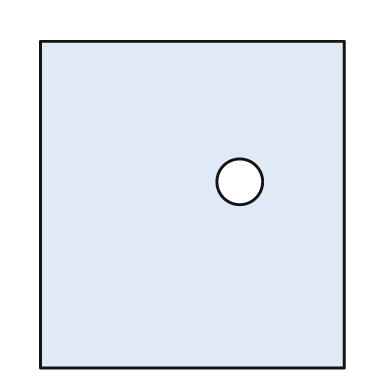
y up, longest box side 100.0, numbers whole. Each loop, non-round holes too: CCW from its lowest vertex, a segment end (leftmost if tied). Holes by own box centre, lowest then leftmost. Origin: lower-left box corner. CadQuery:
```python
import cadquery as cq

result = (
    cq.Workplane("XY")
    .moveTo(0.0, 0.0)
    .lineTo(93.0, 0.0)
    .lineTo(93.0, 100.0)
    .lineTo(0.0, 100.0)
    .close()
    .moveTo(61.0, 57.0)
    .circle(7.0)
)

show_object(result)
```